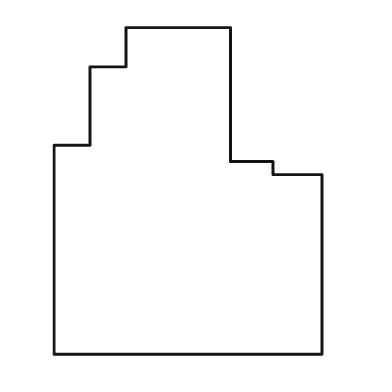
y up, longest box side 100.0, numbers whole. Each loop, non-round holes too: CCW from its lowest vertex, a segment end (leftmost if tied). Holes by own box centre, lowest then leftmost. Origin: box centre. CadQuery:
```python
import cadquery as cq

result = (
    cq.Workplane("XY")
    .moveTo(-41.0, -50.0)
    .lineTo(41.0, -50.0)
    .lineTo(41.0, 5.0)
    .lineTo(26.0, 5.0)
    .lineTo(26.0, 9.0)
    .lineTo(13.0, 9.0)
    .lineTo(13.0, 50.0)
    .lineTo(-19.0, 50.0)
    .lineTo(-19.0, 38.0)
    .lineTo(-30.0, 38.0)
    .lineTo(-30.0, 14.0)
    .lineTo(-41.0, 14.0)
    .close()
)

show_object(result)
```